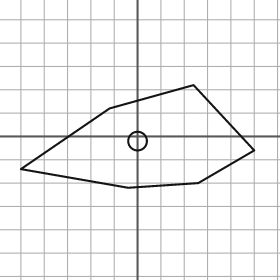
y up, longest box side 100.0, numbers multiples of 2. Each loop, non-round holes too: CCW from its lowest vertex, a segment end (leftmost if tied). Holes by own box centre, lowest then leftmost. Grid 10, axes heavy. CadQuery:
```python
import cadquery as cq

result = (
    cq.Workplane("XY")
    .moveTo(-4.0, -22.0)
    .lineTo(26.0, -20.0)
    .lineTo(50.0, -6.0)
    .lineTo(24.0, 22.0)
    .lineTo(-12.0, 12.0)
    .lineTo(-50.0, -14.0)
    .close()
    .moveTo(0.0, -2.0)
    .circle(4.0)
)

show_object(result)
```